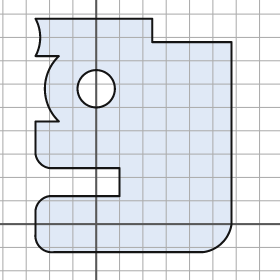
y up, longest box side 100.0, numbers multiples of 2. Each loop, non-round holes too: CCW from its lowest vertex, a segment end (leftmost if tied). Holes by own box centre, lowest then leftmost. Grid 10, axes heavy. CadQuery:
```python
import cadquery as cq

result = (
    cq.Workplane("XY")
    .moveTo(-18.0, -12.0)
    .lineTo(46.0, -12.0)
    .threePointArc((54.0, -8.0), (58.0, 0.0))
    .lineTo(58.0, 78.0)
    .lineTo(24.0, 78.0)
    .lineTo(24.0, 88.0)
    .lineTo(-26.0, 88.0)
    .threePointArc((-24.0, 80.0), (-26.0, 72.0))
    .lineTo(-16.0, 72.0)
    .threePointArc((-22.0, 58.0), (-16.0, 44.0))
    .lineTo(-26.0, 44.0)
    .lineTo(-26.0, 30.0)
    .threePointArc((-24.0, 26.0), (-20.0, 24.0))
    .lineTo(10.0, 24.0)
    .lineTo(10.0, 12.0)
    .lineTo(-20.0, 12.0)
    .threePointArc((-24.0, 10.0), (-26.0, 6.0))
    .lineTo(-26.0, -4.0)
    .threePointArc((-24.0, -10.0), (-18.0, -12.0))
    .close()
    .moveTo(0.0, 58.0)
    .circle(8.0)
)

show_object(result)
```